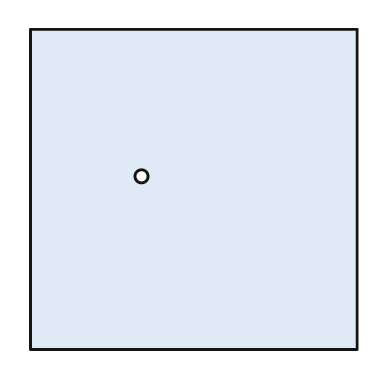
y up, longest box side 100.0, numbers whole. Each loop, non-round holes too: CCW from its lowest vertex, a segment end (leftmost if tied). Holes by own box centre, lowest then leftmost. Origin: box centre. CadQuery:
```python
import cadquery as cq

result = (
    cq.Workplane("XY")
    .moveTo(-50.0, -49.0)
    .lineTo(50.0, -49.0)
    .lineTo(50.0, 49.0)
    .lineTo(-50.0, 49.0)
    .close()
    .moveTo(-16.0, 4.0)
    .circle(2.0)
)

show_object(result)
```